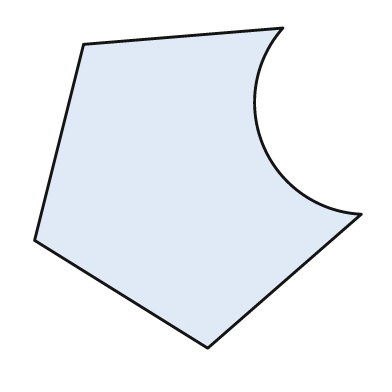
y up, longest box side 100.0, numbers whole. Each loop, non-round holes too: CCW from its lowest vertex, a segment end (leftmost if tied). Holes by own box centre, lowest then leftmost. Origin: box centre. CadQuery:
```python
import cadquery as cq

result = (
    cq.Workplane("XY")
    .moveTo(3.0, -49.0)
    .lineTo(50.0, -8.0)
    .threePointArc((20.0, 13.0), (26.0, 49.0))
    .lineTo(-35.0, 44.0)
    .lineTo(-50.0, -16.0)
    .close()
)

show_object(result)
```